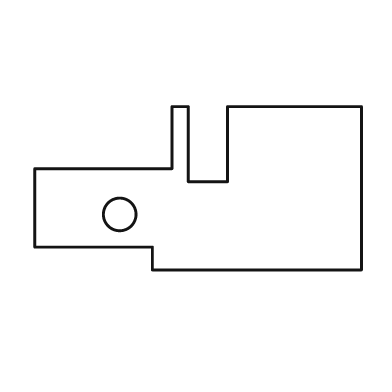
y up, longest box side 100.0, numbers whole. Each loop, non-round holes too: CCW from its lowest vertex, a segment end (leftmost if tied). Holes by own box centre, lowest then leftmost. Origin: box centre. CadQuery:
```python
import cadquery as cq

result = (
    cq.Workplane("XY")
    .moveTo(-14.0, -25.0)
    .lineTo(50.0, -25.0)
    .lineTo(50.0, 25.0)
    .lineTo(9.0, 25.0)
    .lineTo(9.0, 2.0)
    .lineTo(-3.0, 2.0)
    .lineTo(-3.0, 25.0)
    .lineTo(-8.0, 25.0)
    .lineTo(-8.0, 6.0)
    .lineTo(-50.0, 6.0)
    .lineTo(-50.0, -18.0)
    .lineTo(-14.0, -18.0)
    .close()
    .moveTo(-24.0, -8.0)
    .circle(5.0)
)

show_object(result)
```